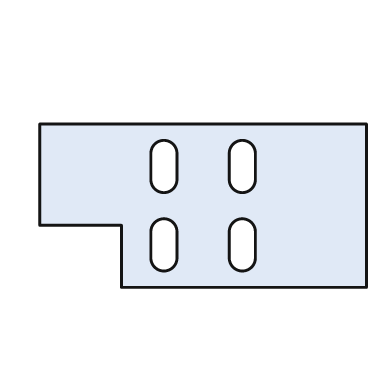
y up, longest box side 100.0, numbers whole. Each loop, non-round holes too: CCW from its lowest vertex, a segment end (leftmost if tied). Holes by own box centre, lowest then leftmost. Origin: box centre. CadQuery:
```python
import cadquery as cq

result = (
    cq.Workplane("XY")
    .moveTo(-25.0, -25.0)
    .lineTo(50.0, -25.0)
    .lineTo(50.0, 25.0)
    .lineTo(-50.0, 25.0)
    .lineTo(-50.0, -6.0)
    .lineTo(-25.0, -6.0)
    .close()
    .moveTo(-16.0, -16.0)
    .threePointArc((-12.0, -20.0), (-8.0, -16.0))
    .lineTo(-8.0, -8.0)
    .threePointArc((-12.0, -4.0), (-16.0, -8.0))
    .close()
    .moveTo(8.0, -16.0)
    .threePointArc((12.0, -20.0), (16.0, -16.0))
    .lineTo(16.0, -8.0)
    .threePointArc((12.0, -4.0), (8.0, -8.0))
    .close()
    .moveTo(-16.0, 8.0)
    .threePointArc((-12.0, 4.0), (-8.0, 8.0))
    .lineTo(-8.0, 16.0)
    .threePointArc((-12.0, 20.0), (-16.0, 16.0))
    .close()
    .moveTo(8.0, 8.0)
    .threePointArc((12.0, 4.0), (16.0, 8.0))
    .lineTo(16.0, 16.0)
    .threePointArc((12.0, 20.0), (8.0, 16.0))
    .close()
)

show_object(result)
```